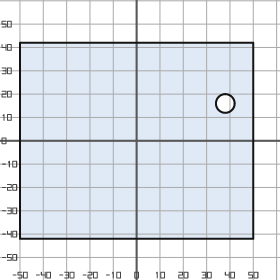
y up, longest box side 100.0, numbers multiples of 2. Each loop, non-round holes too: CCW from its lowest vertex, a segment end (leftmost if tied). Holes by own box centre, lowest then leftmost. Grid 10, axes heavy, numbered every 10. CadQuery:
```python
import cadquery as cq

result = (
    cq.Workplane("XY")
    .moveTo(-50.0, -42.0)
    .lineTo(50.0, -42.0)
    .lineTo(50.0, 42.0)
    .lineTo(-50.0, 42.0)
    .close()
    .moveTo(38.0, 16.0)
    .circle(4.0)
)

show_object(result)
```